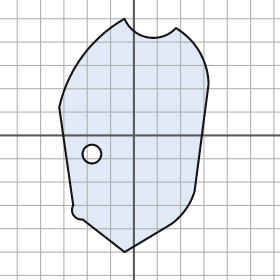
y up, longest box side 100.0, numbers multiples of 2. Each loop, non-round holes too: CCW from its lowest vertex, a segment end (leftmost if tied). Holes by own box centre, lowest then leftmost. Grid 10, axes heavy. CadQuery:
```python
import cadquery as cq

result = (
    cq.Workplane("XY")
    .moveTo(-4.0, -50.0)
    .lineTo(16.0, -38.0)
    .threePointArc((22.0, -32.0), (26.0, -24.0))
    .lineTo(32.0, 22.0)
    .threePointArc((28.0, 36.0), (18.0, 46.0))
    .threePointArc((6.0, 42.0), (-4.0, 50.0))
    .threePointArc((-22.0, 34.0), (-32.0, 12.0))
    .lineTo(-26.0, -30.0)
    .threePointArc((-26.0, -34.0), (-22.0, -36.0))
    .close()
    .moveTo(-18.0, -8.0)
    .circle(4.0)
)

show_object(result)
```